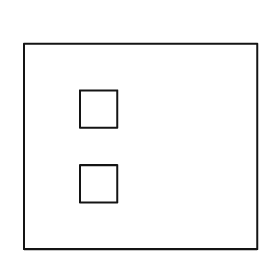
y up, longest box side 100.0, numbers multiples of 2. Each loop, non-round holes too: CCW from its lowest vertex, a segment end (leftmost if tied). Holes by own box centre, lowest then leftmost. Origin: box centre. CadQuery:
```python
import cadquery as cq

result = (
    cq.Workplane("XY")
    .moveTo(-50.0, -44.0)
    .lineTo(50.0, -44.0)
    .lineTo(50.0, 44.0)
    .lineTo(-50.0, 44.0)
    .close()
    .moveTo(-26.0, -24.0)
    .lineTo(-10.0, -24.0)
    .lineTo(-10.0, -8.0)
    .lineTo(-26.0, -8.0)
    .close()
    .moveTo(-26.0, 8.0)
    .lineTo(-10.0, 8.0)
    .lineTo(-10.0, 24.0)
    .lineTo(-26.0, 24.0)
    .close()
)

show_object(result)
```